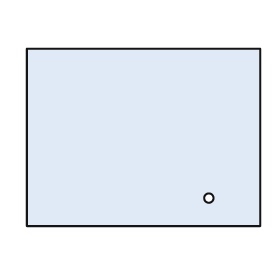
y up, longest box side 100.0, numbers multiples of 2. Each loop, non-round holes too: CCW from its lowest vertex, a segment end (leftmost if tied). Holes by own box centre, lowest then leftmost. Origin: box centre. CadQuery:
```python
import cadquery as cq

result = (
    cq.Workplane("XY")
    .moveTo(-50.0, -38.0)
    .lineTo(50.0, -38.0)
    .lineTo(50.0, 38.0)
    .lineTo(-50.0, 38.0)
    .close()
    .moveTo(28.0, -26.0)
    .circle(2.0)
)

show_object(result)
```